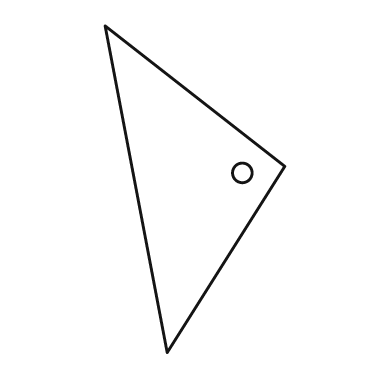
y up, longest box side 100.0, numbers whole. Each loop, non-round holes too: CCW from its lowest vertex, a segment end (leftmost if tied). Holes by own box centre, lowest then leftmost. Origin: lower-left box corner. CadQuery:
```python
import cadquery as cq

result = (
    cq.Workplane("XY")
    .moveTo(19.0, 0.0)
    .lineTo(55.0, 57.0)
    .lineTo(0.0, 100.0)
    .close()
    .moveTo(42.0, 55.0)
    .circle(3.0)
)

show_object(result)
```